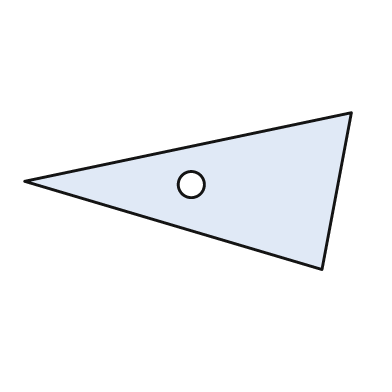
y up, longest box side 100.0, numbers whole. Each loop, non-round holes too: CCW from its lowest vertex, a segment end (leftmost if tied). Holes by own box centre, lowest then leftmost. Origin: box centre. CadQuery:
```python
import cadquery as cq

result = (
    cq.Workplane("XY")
    .moveTo(41.0, -24.0)
    .lineTo(50.0, 24.0)
    .lineTo(-50.0, 3.0)
    .close()
    .moveTo(1.0, 2.0)
    .circle(4.0)
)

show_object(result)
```